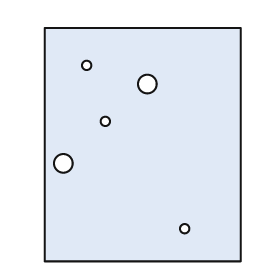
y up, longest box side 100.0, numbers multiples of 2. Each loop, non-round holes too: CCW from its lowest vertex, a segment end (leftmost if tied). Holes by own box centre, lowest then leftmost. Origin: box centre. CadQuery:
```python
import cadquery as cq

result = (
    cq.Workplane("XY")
    .moveTo(-42.0, -50.0)
    .lineTo(42.0, -50.0)
    .lineTo(42.0, 50.0)
    .lineTo(-42.0, 50.0)
    .close()
    .moveTo(18.0, -36.0)
    .circle(2.0)
    .moveTo(-34.0, -8.0)
    .circle(4.0)
    .moveTo(-16.0, 10.0)
    .circle(2.0)
    .moveTo(2.0, 26.0)
    .circle(4.0)
    .moveTo(-24.0, 34.0)
    .circle(2.0)
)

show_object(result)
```